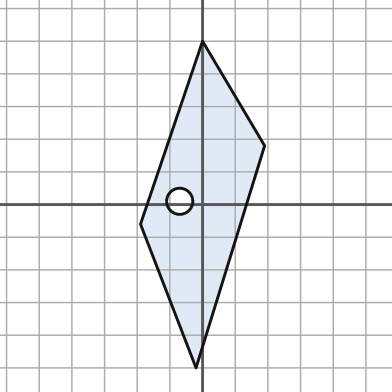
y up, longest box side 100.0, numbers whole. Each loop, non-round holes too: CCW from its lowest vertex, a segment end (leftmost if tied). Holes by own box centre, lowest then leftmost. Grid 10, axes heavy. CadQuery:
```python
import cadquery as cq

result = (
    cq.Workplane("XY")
    .moveTo(-2.0, -50.0)
    .lineTo(19.0, 18.0)
    .lineTo(0.0, 50.0)
    .lineTo(-19.0, -6.0)
    .close()
    .moveTo(-7.0, 1.0)
    .circle(4.0)
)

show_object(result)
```